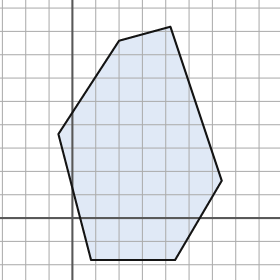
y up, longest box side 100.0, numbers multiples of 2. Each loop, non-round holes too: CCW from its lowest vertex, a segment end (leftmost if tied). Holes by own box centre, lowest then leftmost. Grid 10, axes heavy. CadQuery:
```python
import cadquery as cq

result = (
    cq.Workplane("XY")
    .moveTo(8.0, -18.0)
    .lineTo(44.0, -18.0)
    .lineTo(64.0, 16.0)
    .lineTo(42.0, 82.0)
    .lineTo(20.0, 76.0)
    .lineTo(-6.0, 36.0)
    .close()
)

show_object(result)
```